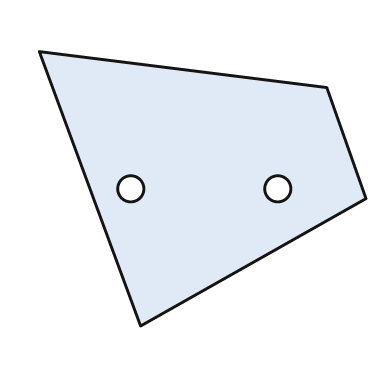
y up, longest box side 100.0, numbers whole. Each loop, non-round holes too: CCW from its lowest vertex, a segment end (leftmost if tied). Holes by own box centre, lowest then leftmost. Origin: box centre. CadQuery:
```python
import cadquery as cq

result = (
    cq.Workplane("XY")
    .moveTo(-19.0, -42.0)
    .lineTo(50.0, -3.0)
    .lineTo(38.0, 31.0)
    .lineTo(-50.0, 42.0)
    .close()
    .moveTo(-22.0, 0.0)
    .circle(4.0)
    .moveTo(23.0, 0.0)
    .circle(4.0)
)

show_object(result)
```